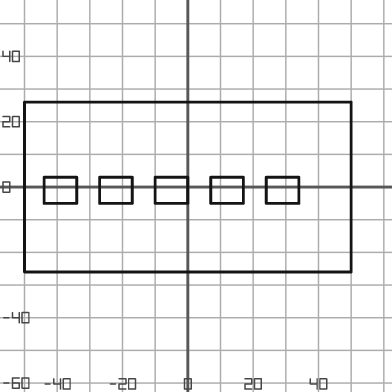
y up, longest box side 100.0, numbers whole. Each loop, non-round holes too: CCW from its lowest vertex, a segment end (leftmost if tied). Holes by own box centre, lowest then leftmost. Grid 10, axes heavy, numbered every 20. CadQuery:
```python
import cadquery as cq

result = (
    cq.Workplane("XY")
    .moveTo(-50.0, -26.0)
    .lineTo(50.0, -26.0)
    .lineTo(50.0, 26.0)
    .lineTo(-50.0, 26.0)
    .close()
    .moveTo(-44.0, -5.0)
    .lineTo(-34.0, -5.0)
    .lineTo(-34.0, 3.0)
    .lineTo(-44.0, 3.0)
    .close()
    .moveTo(-27.0, -5.0)
    .lineTo(-17.0, -5.0)
    .lineTo(-17.0, 3.0)
    .lineTo(-27.0, 3.0)
    .close()
    .moveTo(-10.0, -5.0)
    .lineTo(0.0, -5.0)
    .lineTo(0.0, 3.0)
    .lineTo(-10.0, 3.0)
    .close()
    .moveTo(7.0, -5.0)
    .lineTo(17.0, -5.0)
    .lineTo(17.0, 3.0)
    .lineTo(7.0, 3.0)
    .close()
    .moveTo(24.0, -5.0)
    .lineTo(34.0, -5.0)
    .lineTo(34.0, 3.0)
    .lineTo(24.0, 3.0)
    .close()
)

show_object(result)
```